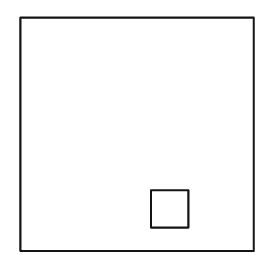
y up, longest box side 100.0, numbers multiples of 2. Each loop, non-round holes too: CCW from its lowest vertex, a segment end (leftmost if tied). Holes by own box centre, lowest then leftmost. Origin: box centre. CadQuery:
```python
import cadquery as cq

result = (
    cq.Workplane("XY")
    .moveTo(-50.0, -50.0)
    .lineTo(50.0, -50.0)
    .lineTo(50.0, 50.0)
    .lineTo(-50.0, 50.0)
    .close()
    .moveTo(6.0, -40.0)
    .lineTo(22.0, -40.0)
    .lineTo(22.0, -24.0)
    .lineTo(6.0, -24.0)
    .close()
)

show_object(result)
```